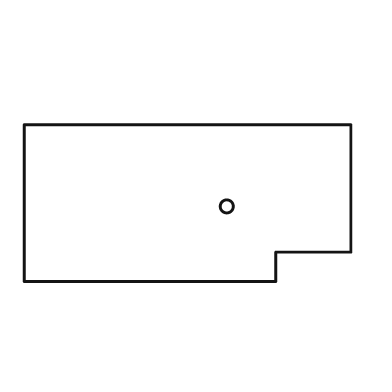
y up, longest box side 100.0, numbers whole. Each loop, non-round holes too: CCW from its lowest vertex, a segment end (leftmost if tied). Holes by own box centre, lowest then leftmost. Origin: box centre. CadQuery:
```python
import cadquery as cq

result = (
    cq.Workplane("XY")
    .moveTo(-50.0, -24.0)
    .lineTo(27.0, -24.0)
    .lineTo(27.0, -15.0)
    .lineTo(50.0, -15.0)
    .lineTo(50.0, 24.0)
    .lineTo(-50.0, 24.0)
    .close()
    .moveTo(12.0, -1.0)
    .circle(2.0)
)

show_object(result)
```